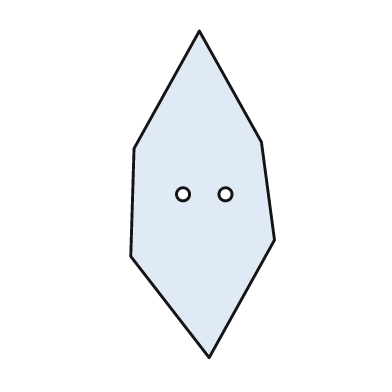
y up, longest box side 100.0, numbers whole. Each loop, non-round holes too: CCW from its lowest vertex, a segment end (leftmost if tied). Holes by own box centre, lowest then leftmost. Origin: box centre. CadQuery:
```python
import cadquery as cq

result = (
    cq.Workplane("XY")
    .moveTo(2.0, -50.0)
    .lineTo(22.0, -14.0)
    .lineTo(18.0, 16.0)
    .lineTo(-1.0, 50.0)
    .lineTo(-21.0, 14.0)
    .lineTo(-22.0, -19.0)
    .close()
    .moveTo(-6.0, 0.0)
    .circle(2.0)
    .moveTo(7.0, 0.0)
    .circle(2.0)
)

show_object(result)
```